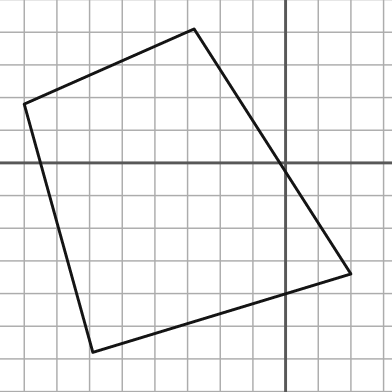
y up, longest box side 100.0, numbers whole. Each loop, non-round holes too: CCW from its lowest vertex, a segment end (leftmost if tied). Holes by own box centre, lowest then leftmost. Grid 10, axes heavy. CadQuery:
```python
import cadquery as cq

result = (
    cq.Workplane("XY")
    .moveTo(-59.0, -58.0)
    .lineTo(20.0, -34.0)
    .lineTo(-28.0, 41.0)
    .lineTo(-80.0, 18.0)
    .close()
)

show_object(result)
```